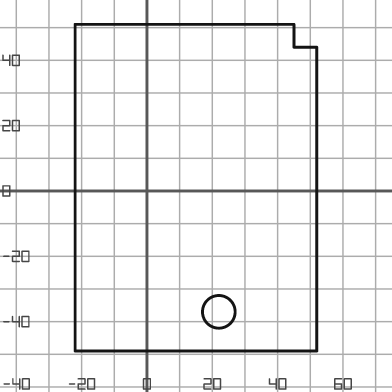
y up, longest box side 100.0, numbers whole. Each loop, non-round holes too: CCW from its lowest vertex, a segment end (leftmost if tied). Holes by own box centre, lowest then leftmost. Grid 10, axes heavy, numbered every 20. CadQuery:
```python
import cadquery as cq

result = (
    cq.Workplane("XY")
    .moveTo(-22.0, -49.0)
    .lineTo(52.0, -49.0)
    .lineTo(52.0, 44.0)
    .lineTo(45.0, 44.0)
    .lineTo(45.0, 51.0)
    .lineTo(-22.0, 51.0)
    .close()
    .moveTo(22.0, -37.0)
    .circle(5.0)
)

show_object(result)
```